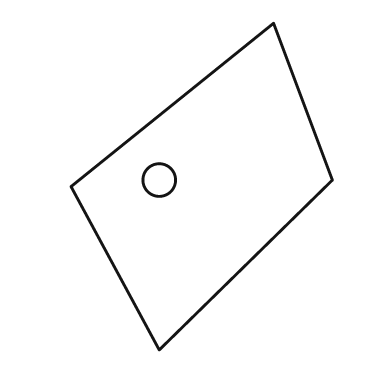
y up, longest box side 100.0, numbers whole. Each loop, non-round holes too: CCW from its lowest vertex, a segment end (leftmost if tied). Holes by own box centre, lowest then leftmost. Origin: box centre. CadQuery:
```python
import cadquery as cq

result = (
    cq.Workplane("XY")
    .moveTo(-13.0, -50.0)
    .lineTo(40.0, 2.0)
    .lineTo(22.0, 50.0)
    .lineTo(-40.0, 0.0)
    .close()
    .moveTo(-13.0, 2.0)
    .circle(5.0)
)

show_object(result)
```